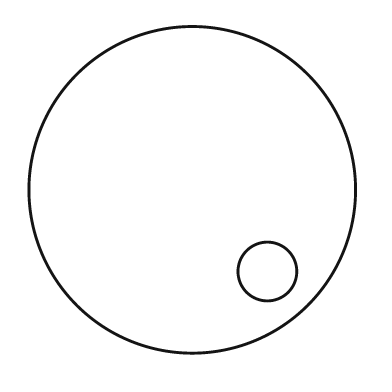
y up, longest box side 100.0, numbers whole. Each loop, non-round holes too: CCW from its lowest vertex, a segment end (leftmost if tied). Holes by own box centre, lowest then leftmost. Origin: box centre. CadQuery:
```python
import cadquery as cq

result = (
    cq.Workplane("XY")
    .moveTo(0.0, 0.0)
    .circle(50.0)
    .moveTo(23.0, -25.0)
    .circle(9.0)
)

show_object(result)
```